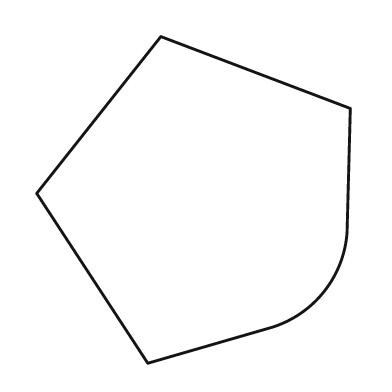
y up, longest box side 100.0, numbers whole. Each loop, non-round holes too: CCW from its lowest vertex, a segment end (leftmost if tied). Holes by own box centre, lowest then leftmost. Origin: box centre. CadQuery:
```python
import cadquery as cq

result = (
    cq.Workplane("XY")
    .moveTo(-14.0, -50.0)
    .lineTo(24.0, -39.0)
    .threePointArc((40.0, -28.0), (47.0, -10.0))
    .lineTo(48.0, 28.0)
    .lineTo(-10.0, 50.0)
    .lineTo(-48.0, 2.0)
    .close()
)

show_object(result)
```